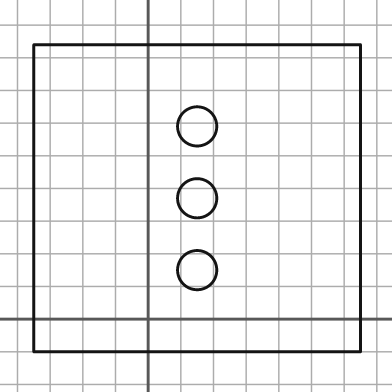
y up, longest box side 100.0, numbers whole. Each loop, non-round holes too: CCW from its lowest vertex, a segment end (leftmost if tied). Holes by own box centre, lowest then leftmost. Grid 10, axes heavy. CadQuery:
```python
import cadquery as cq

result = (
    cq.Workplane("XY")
    .moveTo(-35.0, -10.0)
    .lineTo(65.0, -10.0)
    .lineTo(65.0, 84.0)
    .lineTo(-35.0, 84.0)
    .close()
    .moveTo(15.0, 15.0)
    .circle(6.0)
    .moveTo(15.0, 37.0)
    .circle(6.0)
    .moveTo(15.0, 59.0)
    .circle(6.0)
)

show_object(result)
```